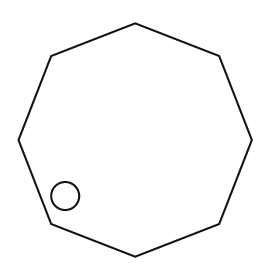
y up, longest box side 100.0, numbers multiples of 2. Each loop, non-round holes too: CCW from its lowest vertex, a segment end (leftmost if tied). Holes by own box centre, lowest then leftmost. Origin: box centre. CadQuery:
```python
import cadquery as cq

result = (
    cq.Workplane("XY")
    .moveTo(0.0, -50.0)
    .lineTo(36.0, -36.0)
    .lineTo(50.0, 0.0)
    .lineTo(36.0, 36.0)
    .lineTo(0.0, 50.0)
    .lineTo(-36.0, 36.0)
    .lineTo(-50.0, 0.0)
    .lineTo(-36.0, -36.0)
    .close()
    .moveTo(-30.0, -24.0)
    .circle(6.0)
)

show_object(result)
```